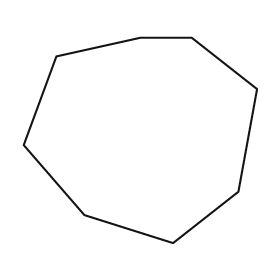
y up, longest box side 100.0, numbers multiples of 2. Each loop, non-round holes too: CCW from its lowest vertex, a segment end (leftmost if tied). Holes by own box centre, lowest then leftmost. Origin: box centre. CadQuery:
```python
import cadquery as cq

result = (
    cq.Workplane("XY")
    .moveTo(14.0, -44.0)
    .lineTo(42.0, -22.0)
    .lineTo(50.0, 22.0)
    .lineTo(22.0, 44.0)
    .lineTo(0.0, 44.0)
    .lineTo(-36.0, 36.0)
    .lineTo(-50.0, -2.0)
    .lineTo(-24.0, -32.0)
    .close()
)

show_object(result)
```